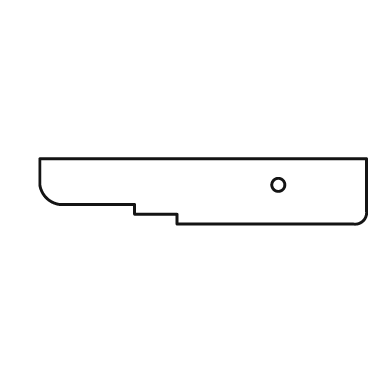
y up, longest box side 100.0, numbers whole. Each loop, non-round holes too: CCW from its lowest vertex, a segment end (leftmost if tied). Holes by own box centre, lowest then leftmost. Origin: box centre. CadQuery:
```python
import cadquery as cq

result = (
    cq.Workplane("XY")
    .moveTo(-8.0, -10.0)
    .lineTo(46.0, -10.0)
    .threePointArc((49.0, -9.0), (50.0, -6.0))
    .lineTo(50.0, 10.0)
    .lineTo(-50.0, 10.0)
    .lineTo(-50.0, 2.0)
    .threePointArc((-48.0, -2.0), (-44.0, -4.0))
    .lineTo(-21.0, -4.0)
    .lineTo(-21.0, -7.0)
    .lineTo(-8.0, -7.0)
    .close()
    .moveTo(23.0, 2.0)
    .circle(2.0)
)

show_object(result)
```